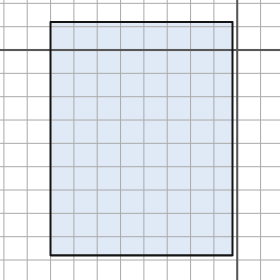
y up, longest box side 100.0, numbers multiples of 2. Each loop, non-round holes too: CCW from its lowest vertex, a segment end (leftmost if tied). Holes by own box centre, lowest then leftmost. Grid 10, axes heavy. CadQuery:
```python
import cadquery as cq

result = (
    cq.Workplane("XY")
    .moveTo(-80.0, -88.0)
    .lineTo(-2.0, -88.0)
    .lineTo(-2.0, 12.0)
    .lineTo(-80.0, 12.0)
    .close()
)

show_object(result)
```